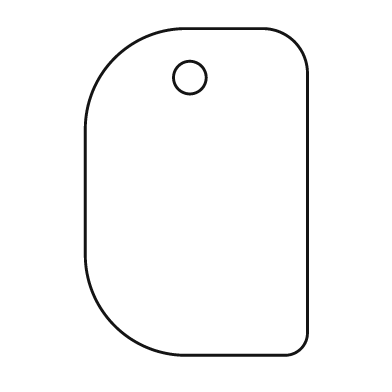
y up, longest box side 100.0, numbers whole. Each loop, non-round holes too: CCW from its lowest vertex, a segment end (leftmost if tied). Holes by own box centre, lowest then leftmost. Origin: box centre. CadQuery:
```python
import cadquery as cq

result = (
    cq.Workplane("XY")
    .moveTo(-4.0, -50.0)
    .lineTo(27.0, -50.0)
    .threePointArc((32.0, -48.0), (34.0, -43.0))
    .lineTo(34.0, 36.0)
    .threePointArc((30.0, 46.0), (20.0, 50.0))
    .lineTo(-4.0, 50.0)
    .threePointArc((-25.0, 41.0), (-34.0, 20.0))
    .lineTo(-34.0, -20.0)
    .threePointArc((-25.0, -41.0), (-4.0, -50.0))
    .close()
    .moveTo(-2.0, 35.0)
    .circle(5.0)
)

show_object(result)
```